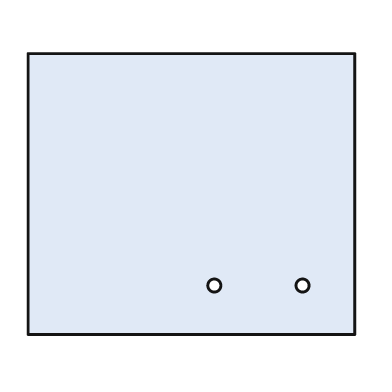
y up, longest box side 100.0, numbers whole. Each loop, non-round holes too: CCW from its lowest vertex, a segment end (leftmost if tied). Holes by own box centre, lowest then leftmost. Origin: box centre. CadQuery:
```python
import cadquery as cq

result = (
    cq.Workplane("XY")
    .moveTo(-50.0, -43.0)
    .lineTo(50.0, -43.0)
    .lineTo(50.0, 43.0)
    .lineTo(-50.0, 43.0)
    .close()
    .moveTo(7.0, -28.0)
    .circle(2.0)
    .moveTo(34.0, -28.0)
    .circle(2.0)
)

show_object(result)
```